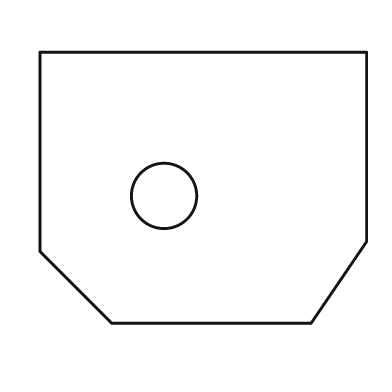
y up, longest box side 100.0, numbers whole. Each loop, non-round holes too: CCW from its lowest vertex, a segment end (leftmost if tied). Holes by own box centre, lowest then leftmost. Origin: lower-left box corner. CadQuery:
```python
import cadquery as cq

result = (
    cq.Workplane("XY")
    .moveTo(22.0, 0.0)
    .lineTo(83.0, 0.0)
    .lineTo(100.0, 25.0)
    .lineTo(100.0, 83.0)
    .lineTo(0.0, 83.0)
    .lineTo(0.0, 22.0)
    .close()
    .moveTo(38.0, 39.0)
    .circle(10.0)
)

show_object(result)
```